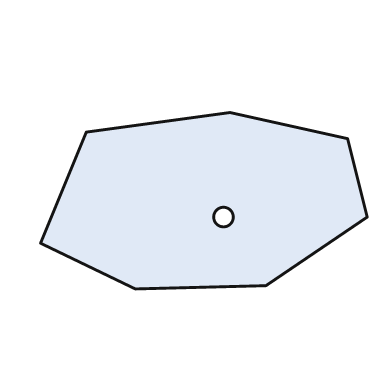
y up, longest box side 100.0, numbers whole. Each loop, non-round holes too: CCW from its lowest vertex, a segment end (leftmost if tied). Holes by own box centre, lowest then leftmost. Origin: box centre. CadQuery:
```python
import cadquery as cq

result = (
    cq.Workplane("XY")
    .moveTo(-21.0, -27.0)
    .lineTo(19.0, -26.0)
    .lineTo(50.0, -5.0)
    .lineTo(44.0, 19.0)
    .lineTo(8.0, 27.0)
    .lineTo(-36.0, 21.0)
    .lineTo(-50.0, -13.0)
    .close()
    .moveTo(6.0, -5.0)
    .circle(3.0)
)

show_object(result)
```